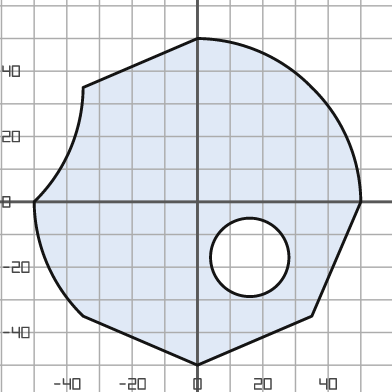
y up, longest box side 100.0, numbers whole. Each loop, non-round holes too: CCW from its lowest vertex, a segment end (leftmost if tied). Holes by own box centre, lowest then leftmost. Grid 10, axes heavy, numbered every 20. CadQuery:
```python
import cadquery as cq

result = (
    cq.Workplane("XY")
    .moveTo(0.0, -50.0)
    .lineTo(35.0, -35.0)
    .lineTo(50.0, 0.0)
    .threePointArc((46.0, 19.0), (35.0, 35.0))
    .threePointArc((19.0, 46.0), (0.0, 50.0))
    .lineTo(-35.0, 35.0)
    .threePointArc((-39.0, 16.0), (-50.0, 0.0))
    .threePointArc((-46.0, -19.0), (-35.0, -35.0))
    .close()
    .moveTo(16.0, -17.0)
    .circle(12.0)
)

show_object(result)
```